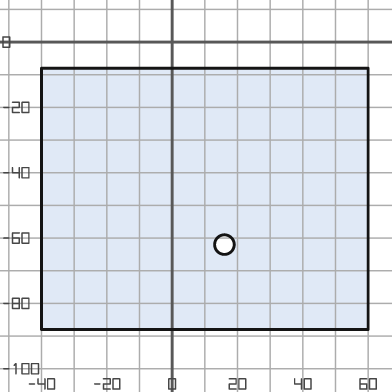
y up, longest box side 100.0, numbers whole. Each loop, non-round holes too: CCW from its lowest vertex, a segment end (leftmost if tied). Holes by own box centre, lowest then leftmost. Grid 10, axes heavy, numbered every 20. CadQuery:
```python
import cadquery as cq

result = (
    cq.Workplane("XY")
    .moveTo(-40.0, -88.0)
    .lineTo(60.0, -88.0)
    .lineTo(60.0, -8.0)
    .lineTo(-40.0, -8.0)
    .close()
    .moveTo(16.0, -62.0)
    .circle(3.0)
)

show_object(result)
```